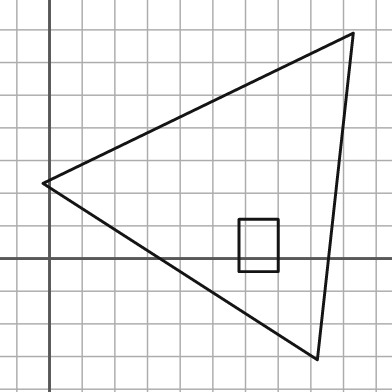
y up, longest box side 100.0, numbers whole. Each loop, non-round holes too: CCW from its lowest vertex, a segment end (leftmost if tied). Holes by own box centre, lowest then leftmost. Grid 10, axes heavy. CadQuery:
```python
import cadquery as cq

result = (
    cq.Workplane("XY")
    .moveTo(82.0, -31.0)
    .lineTo(93.0, 69.0)
    .lineTo(-2.0, 23.0)
    .close()
    .moveTo(58.0, -4.0)
    .lineTo(70.0, -4.0)
    .lineTo(70.0, 12.0)
    .lineTo(58.0, 12.0)
    .close()
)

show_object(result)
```